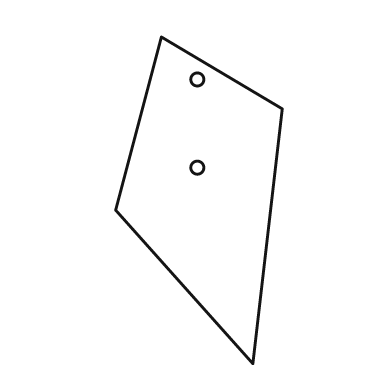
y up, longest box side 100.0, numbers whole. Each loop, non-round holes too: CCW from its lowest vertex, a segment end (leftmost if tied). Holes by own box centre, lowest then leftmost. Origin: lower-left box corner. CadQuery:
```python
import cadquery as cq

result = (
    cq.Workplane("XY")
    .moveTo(42.0, 0.0)
    .lineTo(51.0, 78.0)
    .lineTo(14.0, 100.0)
    .lineTo(0.0, 47.0)
    .close()
    .moveTo(25.0, 60.0)
    .circle(2.0)
    .moveTo(25.0, 87.0)
    .circle(2.0)
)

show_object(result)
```